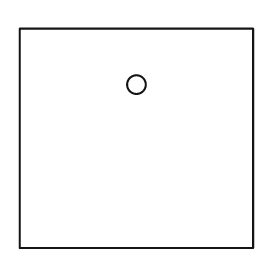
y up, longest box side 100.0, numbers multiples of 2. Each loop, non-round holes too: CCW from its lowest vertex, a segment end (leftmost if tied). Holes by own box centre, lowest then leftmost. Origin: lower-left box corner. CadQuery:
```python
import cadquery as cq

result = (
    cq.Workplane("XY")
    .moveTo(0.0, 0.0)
    .lineTo(100.0, 0.0)
    .lineTo(100.0, 94.0)
    .lineTo(0.0, 94.0)
    .close()
    .moveTo(50.0, 70.0)
    .circle(4.0)
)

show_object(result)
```